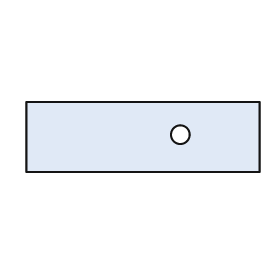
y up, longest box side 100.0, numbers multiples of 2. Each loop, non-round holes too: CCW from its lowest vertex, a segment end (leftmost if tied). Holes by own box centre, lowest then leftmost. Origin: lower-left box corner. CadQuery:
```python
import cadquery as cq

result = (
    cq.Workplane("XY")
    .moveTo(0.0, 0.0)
    .lineTo(100.0, 0.0)
    .lineTo(100.0, 30.0)
    .lineTo(0.0, 30.0)
    .close()
    .moveTo(66.0, 16.0)
    .circle(4.0)
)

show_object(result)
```